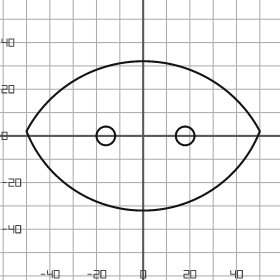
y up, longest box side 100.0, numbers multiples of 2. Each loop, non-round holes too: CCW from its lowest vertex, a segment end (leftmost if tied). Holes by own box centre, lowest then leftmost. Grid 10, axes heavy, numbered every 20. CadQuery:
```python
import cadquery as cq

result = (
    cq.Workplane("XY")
    .moveTo(-50.0, 2.0)
    .threePointArc((0.0, -32.0), (50.0, 2.0))
    .threePointArc((0.0, 32.0), (-50.0, 2.0))
    .close()
    .moveTo(-16.0, 0.0)
    .circle(4.0)
    .moveTo(18.0, 0.0)
    .circle(4.0)
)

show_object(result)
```